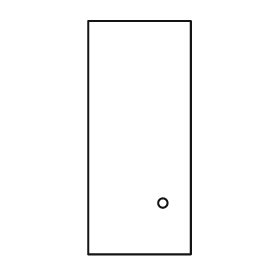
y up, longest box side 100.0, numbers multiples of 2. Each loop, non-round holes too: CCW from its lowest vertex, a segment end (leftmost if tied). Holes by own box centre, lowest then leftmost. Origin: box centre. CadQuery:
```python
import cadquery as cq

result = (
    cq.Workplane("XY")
    .moveTo(-22.0, -50.0)
    .lineTo(22.0, -50.0)
    .lineTo(22.0, 50.0)
    .lineTo(-22.0, 50.0)
    .close()
    .moveTo(10.0, -28.0)
    .circle(2.0)
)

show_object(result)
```